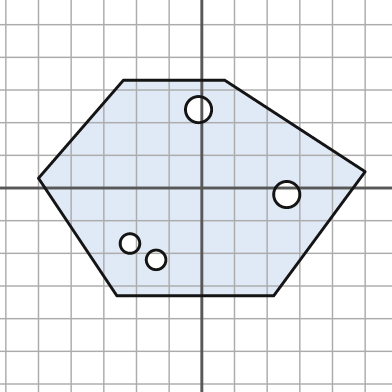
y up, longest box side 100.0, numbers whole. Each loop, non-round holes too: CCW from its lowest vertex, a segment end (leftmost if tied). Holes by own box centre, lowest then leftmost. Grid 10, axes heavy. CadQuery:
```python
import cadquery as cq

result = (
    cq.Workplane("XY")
    .moveTo(-26.0, -33.0)
    .lineTo(22.0, -33.0)
    .lineTo(50.0, 5.0)
    .lineTo(7.0, 33.0)
    .lineTo(-24.0, 33.0)
    .lineTo(-50.0, 3.0)
    .close()
    .moveTo(-14.0, -22.0)
    .circle(3.0)
    .moveTo(-22.0, -17.0)
    .circle(3.0)
    .moveTo(26.0, -2.0)
    .circle(4.0)
    .moveTo(-1.0, 24.0)
    .circle(4.0)
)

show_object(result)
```